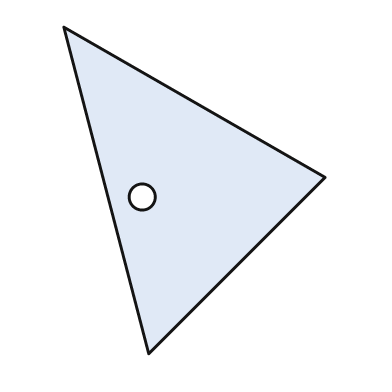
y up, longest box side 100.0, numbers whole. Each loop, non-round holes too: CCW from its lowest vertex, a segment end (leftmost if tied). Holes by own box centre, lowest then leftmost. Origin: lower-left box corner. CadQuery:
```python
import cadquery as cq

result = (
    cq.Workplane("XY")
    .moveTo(26.0, 0.0)
    .lineTo(80.0, 54.0)
    .lineTo(0.0, 100.0)
    .close()
    .moveTo(24.0, 48.0)
    .circle(4.0)
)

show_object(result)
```